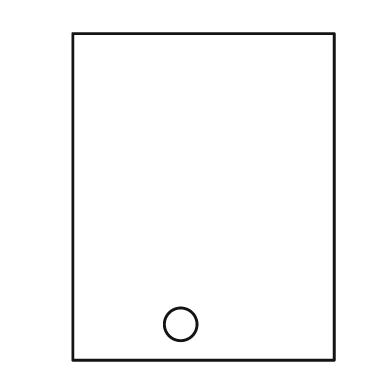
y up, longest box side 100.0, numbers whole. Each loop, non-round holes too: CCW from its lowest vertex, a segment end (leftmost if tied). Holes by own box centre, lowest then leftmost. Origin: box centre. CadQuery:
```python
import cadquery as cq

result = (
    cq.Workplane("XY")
    .moveTo(-40.0, -50.0)
    .lineTo(40.0, -50.0)
    .lineTo(40.0, 50.0)
    .lineTo(-40.0, 50.0)
    .close()
    .moveTo(-7.0, -39.0)
    .circle(5.0)
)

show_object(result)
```